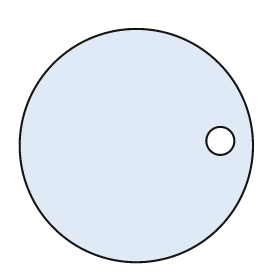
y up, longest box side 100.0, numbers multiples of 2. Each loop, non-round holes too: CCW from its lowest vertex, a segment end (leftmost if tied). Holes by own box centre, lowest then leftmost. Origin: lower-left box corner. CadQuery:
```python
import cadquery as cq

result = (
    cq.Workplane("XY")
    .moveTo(50.0, 50.0)
    .circle(50.0)
    .moveTo(86.0, 52.0)
    .circle(6.0)
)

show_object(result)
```